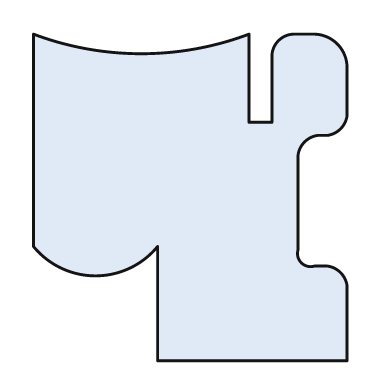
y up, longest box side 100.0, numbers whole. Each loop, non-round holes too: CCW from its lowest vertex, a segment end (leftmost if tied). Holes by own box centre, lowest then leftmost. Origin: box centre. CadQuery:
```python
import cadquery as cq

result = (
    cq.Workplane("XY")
    .moveTo(-10.0, -50.0)
    .lineTo(48.0, -50.0)
    .lineTo(48.0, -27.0)
    .threePointArc((46.0, -23.0), (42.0, -21.0))
    .lineTo(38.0, -21.0)
    .threePointArc((34.0, -20.0), (33.0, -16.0))
    .lineTo(33.0, 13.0)
    .threePointArc((35.0, 17.0), (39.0, 19.0))
    .lineTo(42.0, 19.0)
    .threePointArc((46.0, 21.0), (48.0, 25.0))
    .lineTo(48.0, 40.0)
    .threePointArc((45.0, 47.0), (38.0, 50.0))
    .lineTo(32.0, 50.0)
    .threePointArc((27.0, 48.0), (25.0, 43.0))
    .lineTo(25.0, 23.0)
    .lineTo(18.0, 23.0)
    .lineTo(18.0, 50.0)
    .threePointArc((-15.0, 44.0), (-48.0, 50.0))
    .lineTo(-48.0, -15.0)
    .threePointArc((-29.0, -24.0), (-10.0, -15.0))
    .close()
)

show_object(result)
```